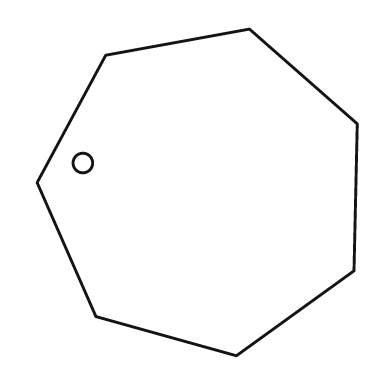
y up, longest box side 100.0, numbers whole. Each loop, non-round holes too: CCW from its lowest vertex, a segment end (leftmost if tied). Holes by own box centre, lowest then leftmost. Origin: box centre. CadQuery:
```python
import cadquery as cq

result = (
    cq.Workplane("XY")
    .moveTo(12.0, -50.0)
    .lineTo(48.0, -24.0)
    .lineTo(49.0, 21.0)
    .lineTo(16.0, 50.0)
    .lineTo(-28.0, 42.0)
    .lineTo(-49.0, 3.0)
    .lineTo(-31.0, -38.0)
    .close()
    .moveTo(-35.0, 9.0)
    .circle(3.0)
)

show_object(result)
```